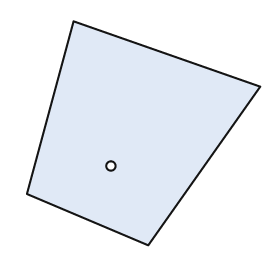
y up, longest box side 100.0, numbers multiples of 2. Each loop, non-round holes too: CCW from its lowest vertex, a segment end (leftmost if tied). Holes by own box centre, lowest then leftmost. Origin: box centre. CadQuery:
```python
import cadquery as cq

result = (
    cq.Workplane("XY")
    .moveTo(2.0, -48.0)
    .lineTo(50.0, 20.0)
    .lineTo(-30.0, 48.0)
    .lineTo(-50.0, -26.0)
    .close()
    .moveTo(-14.0, -14.0)
    .circle(2.0)
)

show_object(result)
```